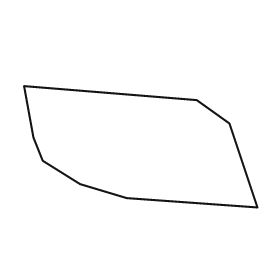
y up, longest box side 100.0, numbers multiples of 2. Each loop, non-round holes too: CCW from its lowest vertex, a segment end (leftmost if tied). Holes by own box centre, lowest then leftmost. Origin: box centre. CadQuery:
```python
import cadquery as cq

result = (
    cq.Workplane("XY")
    .moveTo(50.0, -26.0)
    .lineTo(38.0, 10.0)
    .lineTo(24.0, 20.0)
    .lineTo(-50.0, 26.0)
    .lineTo(-46.0, 4.0)
    .lineTo(-42.0, -6.0)
    .lineTo(-26.0, -16.0)
    .lineTo(-6.0, -22.0)
    .close()
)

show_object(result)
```